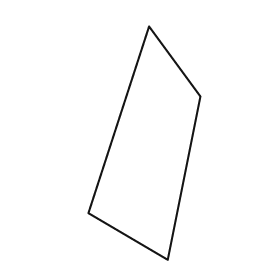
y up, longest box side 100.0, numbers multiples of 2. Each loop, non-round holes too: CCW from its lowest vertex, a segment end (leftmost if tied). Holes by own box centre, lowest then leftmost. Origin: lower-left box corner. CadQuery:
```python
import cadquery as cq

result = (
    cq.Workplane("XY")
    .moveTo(34.0, 0.0)
    .lineTo(48.0, 70.0)
    .lineTo(26.0, 100.0)
    .lineTo(0.0, 20.0)
    .close()
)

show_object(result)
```